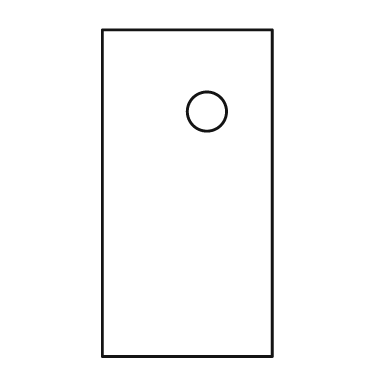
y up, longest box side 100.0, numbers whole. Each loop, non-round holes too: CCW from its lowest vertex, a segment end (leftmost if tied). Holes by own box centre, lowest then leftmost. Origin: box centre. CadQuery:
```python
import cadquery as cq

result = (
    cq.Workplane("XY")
    .moveTo(-26.0, -50.0)
    .lineTo(26.0, -50.0)
    .lineTo(26.0, 50.0)
    .lineTo(-26.0, 50.0)
    .close()
    .moveTo(6.0, 25.0)
    .circle(6.0)
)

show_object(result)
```